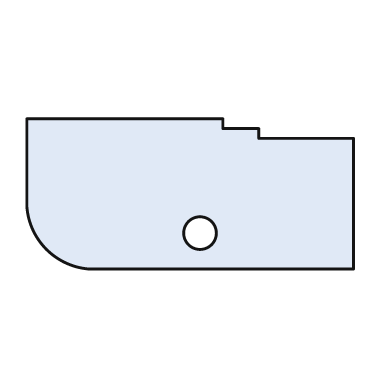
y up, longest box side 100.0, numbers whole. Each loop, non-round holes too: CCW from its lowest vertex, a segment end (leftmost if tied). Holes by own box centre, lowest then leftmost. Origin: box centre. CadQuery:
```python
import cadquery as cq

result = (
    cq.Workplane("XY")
    .moveTo(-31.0, -23.0)
    .lineTo(50.0, -23.0)
    .lineTo(50.0, 17.0)
    .lineTo(21.0, 17.0)
    .lineTo(21.0, 20.0)
    .lineTo(10.0, 20.0)
    .lineTo(10.0, 23.0)
    .lineTo(-50.0, 23.0)
    .lineTo(-50.0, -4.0)
    .threePointArc((-44.0, -17.0), (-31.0, -23.0))
    .close()
    .moveTo(3.0, -12.0)
    .circle(5.0)
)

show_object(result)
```